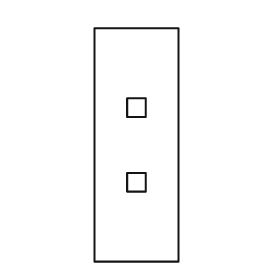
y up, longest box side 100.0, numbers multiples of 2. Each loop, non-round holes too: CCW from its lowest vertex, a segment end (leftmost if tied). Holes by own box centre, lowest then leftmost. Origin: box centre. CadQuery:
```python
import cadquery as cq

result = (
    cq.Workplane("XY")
    .moveTo(-18.0, -50.0)
    .lineTo(18.0, -50.0)
    .lineTo(18.0, 50.0)
    .lineTo(-18.0, 50.0)
    .close()
    .moveTo(-4.0, -20.0)
    .lineTo(4.0, -20.0)
    .lineTo(4.0, -12.0)
    .lineTo(-4.0, -12.0)
    .close()
    .moveTo(-4.0, 12.0)
    .lineTo(4.0, 12.0)
    .lineTo(4.0, 20.0)
    .lineTo(-4.0, 20.0)
    .close()
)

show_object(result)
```